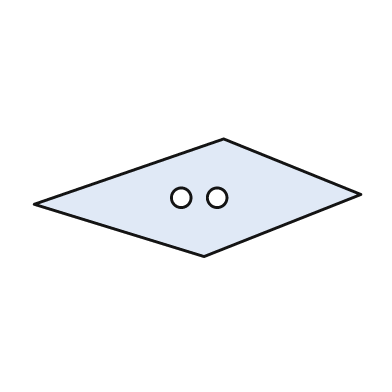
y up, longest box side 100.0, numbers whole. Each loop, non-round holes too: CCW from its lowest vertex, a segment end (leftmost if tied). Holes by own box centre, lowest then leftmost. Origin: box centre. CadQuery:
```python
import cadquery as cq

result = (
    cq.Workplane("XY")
    .moveTo(2.0, -18.0)
    .lineTo(50.0, 1.0)
    .lineTo(8.0, 18.0)
    .lineTo(-50.0, -2.0)
    .close()
    .moveTo(-5.0, 0.0)
    .circle(3.0)
    .moveTo(6.0, 0.0)
    .circle(3.0)
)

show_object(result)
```